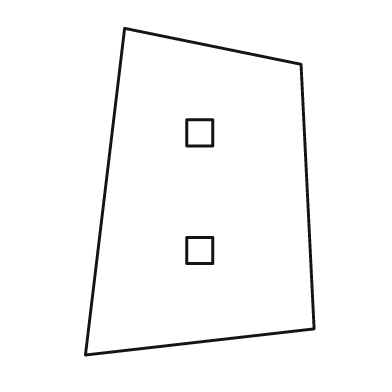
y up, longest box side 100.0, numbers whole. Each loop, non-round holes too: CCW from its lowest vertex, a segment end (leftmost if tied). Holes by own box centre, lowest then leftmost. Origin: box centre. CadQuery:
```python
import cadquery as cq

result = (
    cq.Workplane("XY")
    .moveTo(-35.0, -50.0)
    .lineTo(35.0, -42.0)
    .lineTo(31.0, 39.0)
    .lineTo(-23.0, 50.0)
    .close()
    .moveTo(-4.0, -22.0)
    .lineTo(4.0, -22.0)
    .lineTo(4.0, -14.0)
    .lineTo(-4.0, -14.0)
    .close()
    .moveTo(-4.0, 14.0)
    .lineTo(4.0, 14.0)
    .lineTo(4.0, 22.0)
    .lineTo(-4.0, 22.0)
    .close()
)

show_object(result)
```